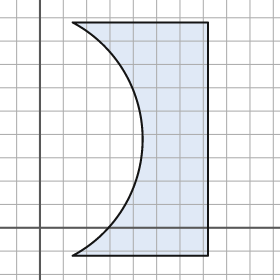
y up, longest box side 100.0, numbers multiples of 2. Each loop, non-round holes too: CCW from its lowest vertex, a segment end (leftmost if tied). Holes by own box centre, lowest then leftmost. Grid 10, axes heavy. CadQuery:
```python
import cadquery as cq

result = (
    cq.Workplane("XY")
    .moveTo(14.0, -12.0)
    .lineTo(72.0, -12.0)
    .lineTo(72.0, 88.0)
    .lineTo(14.0, 88.0)
    .threePointArc((44.0, 38.0), (14.0, -12.0))
    .close()
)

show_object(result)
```